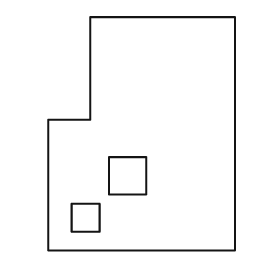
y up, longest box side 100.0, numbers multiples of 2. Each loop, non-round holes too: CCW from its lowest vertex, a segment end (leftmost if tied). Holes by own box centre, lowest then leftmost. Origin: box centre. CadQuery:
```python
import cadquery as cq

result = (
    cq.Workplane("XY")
    .moveTo(-40.0, -50.0)
    .lineTo(40.0, -50.0)
    .lineTo(40.0, 50.0)
    .lineTo(-22.0, 50.0)
    .lineTo(-22.0, 6.0)
    .lineTo(-40.0, 6.0)
    .close()
    .moveTo(-30.0, -42.0)
    .lineTo(-18.0, -42.0)
    .lineTo(-18.0, -30.0)
    .lineTo(-30.0, -30.0)
    .close()
    .moveTo(-14.0, -26.0)
    .lineTo(2.0, -26.0)
    .lineTo(2.0, -10.0)
    .lineTo(-14.0, -10.0)
    .close()
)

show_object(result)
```